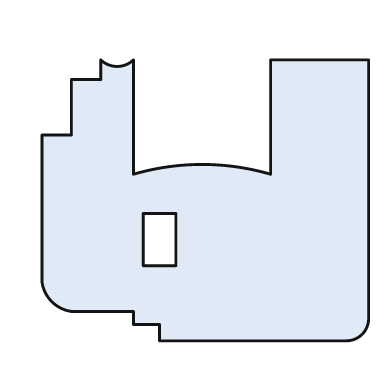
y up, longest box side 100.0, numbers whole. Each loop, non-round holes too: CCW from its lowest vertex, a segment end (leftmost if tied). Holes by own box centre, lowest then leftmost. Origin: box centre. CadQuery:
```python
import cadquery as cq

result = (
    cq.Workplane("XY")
    .moveTo(-14.0, -43.0)
    .lineTo(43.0, -43.0)
    .threePointArc((48.0, -41.0), (50.0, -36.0))
    .lineTo(50.0, 43.0)
    .lineTo(20.0, 43.0)
    .lineTo(20.0, 8.0)
    .threePointArc((-1.0, 11.0), (-22.0, 8.0))
    .lineTo(-22.0, 43.0)
    .threePointArc((-27.0, 41.0), (-32.0, 43.0))
    .lineTo(-32.0, 37.0)
    .lineTo(-41.0, 37.0)
    .lineTo(-41.0, 20.0)
    .lineTo(-50.0, 20.0)
    .lineTo(-50.0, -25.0)
    .threePointArc((-47.0, -31.0), (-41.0, -34.0))
    .lineTo(-22.0, -34.0)
    .lineTo(-22.0, -38.0)
    .lineTo(-14.0, -38.0)
    .close()
    .moveTo(-19.0, -20.0)
    .lineTo(-9.0, -20.0)
    .lineTo(-9.0, -4.0)
    .lineTo(-19.0, -4.0)
    .close()
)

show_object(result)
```